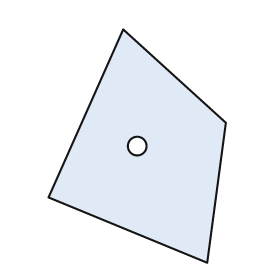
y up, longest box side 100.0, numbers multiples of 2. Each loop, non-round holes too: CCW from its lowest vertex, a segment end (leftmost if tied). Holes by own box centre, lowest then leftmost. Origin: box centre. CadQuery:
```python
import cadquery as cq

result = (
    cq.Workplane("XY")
    .moveTo(30.0, -50.0)
    .lineTo(38.0, 10.0)
    .lineTo(-6.0, 50.0)
    .lineTo(-38.0, -22.0)
    .close()
    .moveTo(0.0, 0.0)
    .circle(4.0)
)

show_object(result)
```